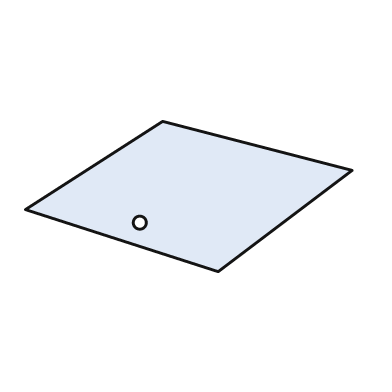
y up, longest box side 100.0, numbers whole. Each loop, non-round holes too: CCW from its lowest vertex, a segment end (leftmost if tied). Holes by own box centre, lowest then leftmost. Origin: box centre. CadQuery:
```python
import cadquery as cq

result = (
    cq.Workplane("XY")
    .moveTo(9.0, -23.0)
    .lineTo(50.0, 8.0)
    .lineTo(-8.0, 23.0)
    .lineTo(-50.0, -4.0)
    .close()
    .moveTo(-15.0, -8.0)
    .circle(2.0)
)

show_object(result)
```